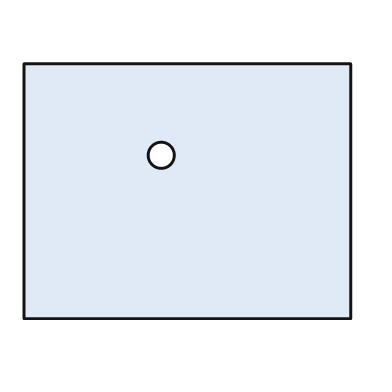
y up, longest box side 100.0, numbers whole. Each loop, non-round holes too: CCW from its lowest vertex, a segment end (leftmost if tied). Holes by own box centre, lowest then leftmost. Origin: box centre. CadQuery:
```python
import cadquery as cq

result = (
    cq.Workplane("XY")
    .moveTo(-50.0, -39.0)
    .lineTo(50.0, -39.0)
    .lineTo(50.0, 39.0)
    .lineTo(-50.0, 39.0)
    .close()
    .moveTo(-8.0, 11.0)
    .circle(4.0)
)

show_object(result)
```